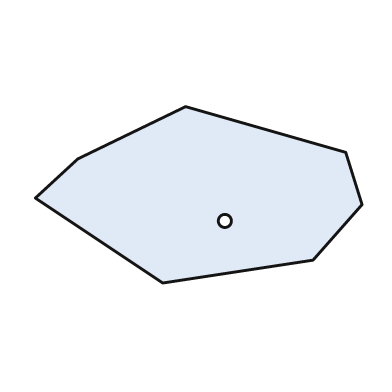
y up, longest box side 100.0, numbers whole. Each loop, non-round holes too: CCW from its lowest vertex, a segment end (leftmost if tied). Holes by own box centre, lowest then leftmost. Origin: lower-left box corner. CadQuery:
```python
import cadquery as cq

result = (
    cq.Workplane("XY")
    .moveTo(39.0, 0.0)
    .lineTo(85.0, 7.0)
    .lineTo(100.0, 24.0)
    .lineTo(95.0, 40.0)
    .lineTo(46.0, 54.0)
    .lineTo(13.0, 38.0)
    .lineTo(0.0, 26.0)
    .close()
    .moveTo(58.0, 19.0)
    .circle(2.0)
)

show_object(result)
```